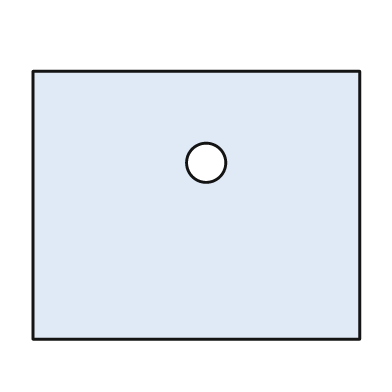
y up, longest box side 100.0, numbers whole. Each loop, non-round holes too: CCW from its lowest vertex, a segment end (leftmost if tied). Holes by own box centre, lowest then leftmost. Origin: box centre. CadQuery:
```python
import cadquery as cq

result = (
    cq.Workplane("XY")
    .moveTo(-50.0, -41.0)
    .lineTo(50.0, -41.0)
    .lineTo(50.0, 41.0)
    .lineTo(-50.0, 41.0)
    .close()
    .moveTo(3.0, 13.0)
    .circle(6.0)
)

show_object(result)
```